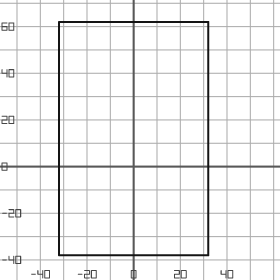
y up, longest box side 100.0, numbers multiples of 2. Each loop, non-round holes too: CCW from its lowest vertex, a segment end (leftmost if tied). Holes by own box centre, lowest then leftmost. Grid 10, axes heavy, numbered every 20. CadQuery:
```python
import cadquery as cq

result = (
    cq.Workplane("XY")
    .moveTo(-32.0, -38.0)
    .lineTo(32.0, -38.0)
    .lineTo(32.0, 62.0)
    .lineTo(-32.0, 62.0)
    .close()
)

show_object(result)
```